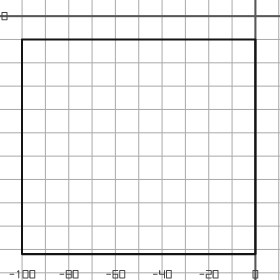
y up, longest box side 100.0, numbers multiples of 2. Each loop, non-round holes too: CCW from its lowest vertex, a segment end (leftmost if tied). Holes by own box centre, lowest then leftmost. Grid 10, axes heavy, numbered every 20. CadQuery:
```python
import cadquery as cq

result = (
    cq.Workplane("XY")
    .moveTo(-100.0, -102.0)
    .lineTo(0.0, -102.0)
    .lineTo(0.0, -10.0)
    .lineTo(-100.0, -10.0)
    .close()
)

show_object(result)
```